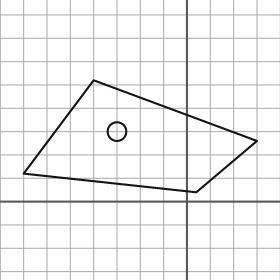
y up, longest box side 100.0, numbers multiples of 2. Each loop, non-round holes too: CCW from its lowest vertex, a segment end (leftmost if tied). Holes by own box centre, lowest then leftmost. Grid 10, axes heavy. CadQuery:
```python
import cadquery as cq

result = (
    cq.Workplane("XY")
    .moveTo(4.0, 4.0)
    .lineTo(30.0, 26.0)
    .lineTo(-40.0, 52.0)
    .lineTo(-70.0, 12.0)
    .close()
    .moveTo(-30.0, 30.0)
    .circle(4.0)
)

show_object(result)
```